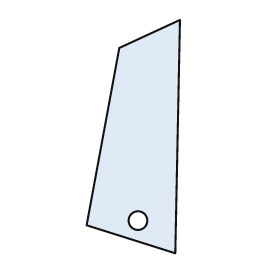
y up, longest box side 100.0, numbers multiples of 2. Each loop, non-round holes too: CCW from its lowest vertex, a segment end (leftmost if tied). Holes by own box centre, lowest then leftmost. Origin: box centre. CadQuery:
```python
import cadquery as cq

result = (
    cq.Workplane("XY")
    .moveTo(18.0, -50.0)
    .lineTo(20.0, 50.0)
    .lineTo(-6.0, 38.0)
    .lineTo(-20.0, -38.0)
    .close()
    .moveTo(2.0, -36.0)
    .circle(4.0)
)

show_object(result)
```